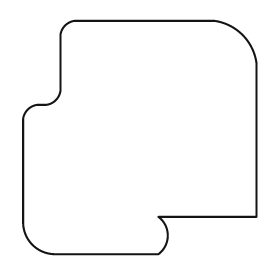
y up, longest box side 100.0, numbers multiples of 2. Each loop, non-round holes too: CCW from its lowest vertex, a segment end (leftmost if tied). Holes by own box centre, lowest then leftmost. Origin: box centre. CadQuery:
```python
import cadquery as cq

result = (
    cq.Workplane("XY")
    .moveTo(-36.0, -50.0)
    .lineTo(8.0, -50.0)
    .threePointArc((12.0, -42.0), (8.0, -34.0))
    .lineTo(50.0, -34.0)
    .lineTo(50.0, 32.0)
    .threePointArc((44.0, 44.0), (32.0, 50.0))
    .lineTo(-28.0, 50.0)
    .threePointArc((-32.0, 48.0), (-34.0, 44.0))
    .lineTo(-34.0, 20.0)
    .threePointArc((-36.0, 16.0), (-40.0, 14.0))
    .lineTo(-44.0, 14.0)
    .threePointArc((-48.0, 12.0), (-50.0, 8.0))
    .lineTo(-50.0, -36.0)
    .threePointArc((-46.0, -46.0), (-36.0, -50.0))
    .close()
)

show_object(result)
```